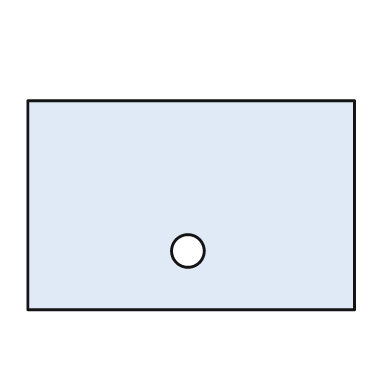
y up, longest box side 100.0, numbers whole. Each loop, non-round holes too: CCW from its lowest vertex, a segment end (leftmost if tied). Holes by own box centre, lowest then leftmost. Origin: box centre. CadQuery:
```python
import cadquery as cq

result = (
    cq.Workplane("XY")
    .moveTo(-50.0, -32.0)
    .lineTo(50.0, -32.0)
    .lineTo(50.0, 32.0)
    .lineTo(-50.0, 32.0)
    .close()
    .moveTo(-1.0, -14.0)
    .circle(5.0)
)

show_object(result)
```